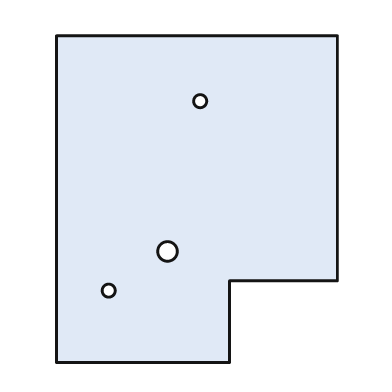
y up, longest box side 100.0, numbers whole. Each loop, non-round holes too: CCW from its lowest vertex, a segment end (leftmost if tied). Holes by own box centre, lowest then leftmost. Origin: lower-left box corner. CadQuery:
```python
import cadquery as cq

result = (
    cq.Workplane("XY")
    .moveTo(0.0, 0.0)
    .lineTo(53.0, 0.0)
    .lineTo(53.0, 25.0)
    .lineTo(86.0, 25.0)
    .lineTo(86.0, 100.0)
    .lineTo(0.0, 100.0)
    .close()
    .moveTo(16.0, 22.0)
    .circle(2.0)
    .moveTo(34.0, 34.0)
    .circle(3.0)
    .moveTo(44.0, 80.0)
    .circle(2.0)
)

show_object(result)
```